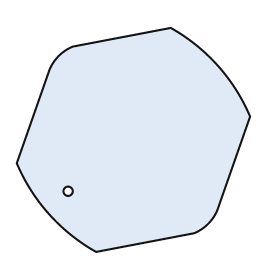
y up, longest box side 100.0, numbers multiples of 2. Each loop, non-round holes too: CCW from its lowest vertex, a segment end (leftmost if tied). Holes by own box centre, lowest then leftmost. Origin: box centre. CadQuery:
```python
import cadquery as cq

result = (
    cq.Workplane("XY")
    .moveTo(-16.0, -48.0)
    .lineTo(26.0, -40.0)
    .threePointArc((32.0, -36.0), (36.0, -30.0))
    .lineTo(50.0, 10.0)
    .threePointArc((36.0, 32.0), (16.0, 48.0))
    .lineTo(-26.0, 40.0)
    .threePointArc((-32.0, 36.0), (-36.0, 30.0))
    .lineTo(-50.0, -10.0)
    .threePointArc((-36.0, -32.0), (-16.0, -48.0))
    .close()
    .moveTo(-28.0, -22.0)
    .circle(2.0)
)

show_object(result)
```